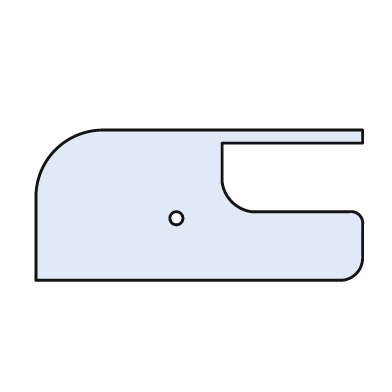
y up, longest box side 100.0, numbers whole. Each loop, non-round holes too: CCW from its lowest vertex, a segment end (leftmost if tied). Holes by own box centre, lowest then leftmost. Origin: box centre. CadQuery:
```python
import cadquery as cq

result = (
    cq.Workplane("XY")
    .moveTo(-50.0, -23.0)
    .lineTo(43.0, -23.0)
    .threePointArc((48.0, -21.0), (50.0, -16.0))
    .lineTo(50.0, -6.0)
    .threePointArc((49.0, -3.0), (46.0, -2.0))
    .lineTo(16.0, -2.0)
    .threePointArc((10.0, 1.0), (7.0, 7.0))
    .lineTo(7.0, 19.0)
    .lineTo(50.0, 19.0)
    .lineTo(50.0, 23.0)
    .lineTo(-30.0, 23.0)
    .threePointArc((-44.0, 17.0), (-50.0, 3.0))
    .close()
    .moveTo(-7.0, -4.0)
    .circle(2.0)
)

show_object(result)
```